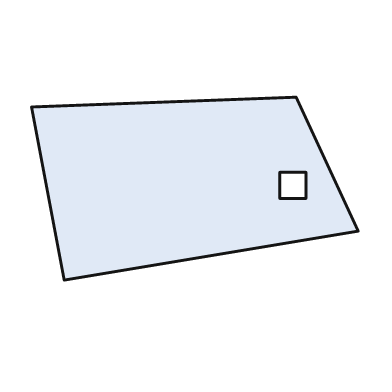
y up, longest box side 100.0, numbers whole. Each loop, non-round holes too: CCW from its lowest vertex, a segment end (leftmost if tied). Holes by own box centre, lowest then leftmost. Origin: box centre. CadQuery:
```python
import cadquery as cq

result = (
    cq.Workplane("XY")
    .moveTo(-40.0, -28.0)
    .lineTo(50.0, -13.0)
    .lineTo(31.0, 28.0)
    .lineTo(-50.0, 25.0)
    .close()
    .moveTo(26.0, -3.0)
    .lineTo(34.0, -3.0)
    .lineTo(34.0, 5.0)
    .lineTo(26.0, 5.0)
    .close()
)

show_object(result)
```